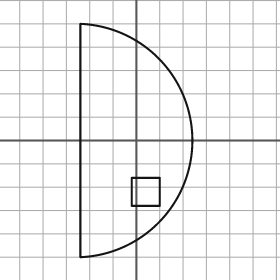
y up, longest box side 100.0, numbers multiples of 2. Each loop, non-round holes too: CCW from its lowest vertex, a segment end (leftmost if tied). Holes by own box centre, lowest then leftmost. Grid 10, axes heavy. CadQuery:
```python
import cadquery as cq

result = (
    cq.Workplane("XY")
    .moveTo(-24.0, -50.0)
    .threePointArc((24.0, 0.0), (-24.0, 50.0))
    .close()
    .moveTo(-2.0, -28.0)
    .lineTo(10.0, -28.0)
    .lineTo(10.0, -16.0)
    .lineTo(-2.0, -16.0)
    .close()
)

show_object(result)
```